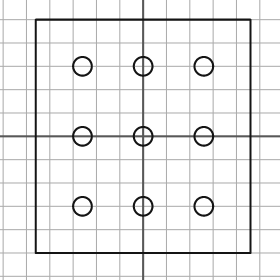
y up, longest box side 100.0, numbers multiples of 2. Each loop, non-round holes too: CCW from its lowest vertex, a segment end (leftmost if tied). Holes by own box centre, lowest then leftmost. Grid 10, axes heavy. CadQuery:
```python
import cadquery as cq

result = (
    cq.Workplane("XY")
    .moveTo(-46.0, -50.0)
    .lineTo(46.0, -50.0)
    .lineTo(46.0, 50.0)
    .lineTo(-46.0, 50.0)
    .close()
    .moveTo(-26.0, -30.0)
    .circle(4.0)
    .moveTo(0.0, -30.0)
    .circle(4.0)
    .moveTo(26.0, -30.0)
    .circle(4.0)
    .moveTo(-26.0, 0.0)
    .circle(4.0)
    .moveTo(0.0, 0.0)
    .circle(4.0)
    .moveTo(26.0, 0.0)
    .circle(4.0)
    .moveTo(-26.0, 30.0)
    .circle(4.0)
    .moveTo(0.0, 30.0)
    .circle(4.0)
    .moveTo(26.0, 30.0)
    .circle(4.0)
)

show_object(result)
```